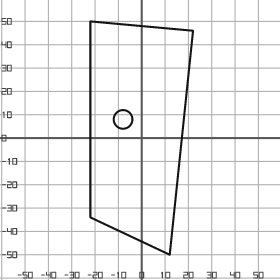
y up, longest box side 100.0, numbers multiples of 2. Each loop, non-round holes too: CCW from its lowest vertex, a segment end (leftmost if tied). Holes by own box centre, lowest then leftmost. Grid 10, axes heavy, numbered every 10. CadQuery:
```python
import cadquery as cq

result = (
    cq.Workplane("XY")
    .moveTo(12.0, -50.0)
    .lineTo(22.0, 46.0)
    .lineTo(-22.0, 50.0)
    .lineTo(-22.0, -34.0)
    .close()
    .moveTo(-8.0, 8.0)
    .circle(4.0)
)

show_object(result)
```